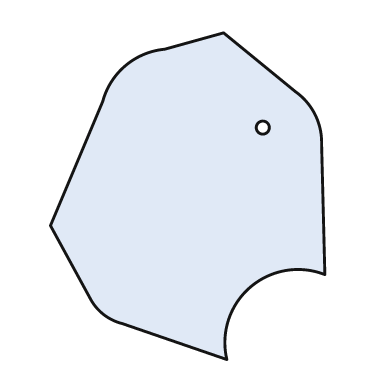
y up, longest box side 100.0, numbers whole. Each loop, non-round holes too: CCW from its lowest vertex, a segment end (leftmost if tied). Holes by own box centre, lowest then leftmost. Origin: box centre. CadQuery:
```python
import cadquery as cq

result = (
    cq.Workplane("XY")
    .moveTo(12.0, -50.0)
    .threePointArc((19.0, -28.0), (42.0, -24.0))
    .lineTo(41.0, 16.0)
    .threePointArc((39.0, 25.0), (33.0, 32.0))
    .lineTo(11.0, 50.0)
    .lineTo(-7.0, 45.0)
    .threePointArc((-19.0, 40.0), (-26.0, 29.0))
    .lineTo(-42.0, -9.0)
    .lineTo(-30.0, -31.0)
    .threePointArc((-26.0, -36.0), (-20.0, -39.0))
    .close()
    .moveTo(23.0, 21.0)
    .circle(2.0)
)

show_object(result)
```